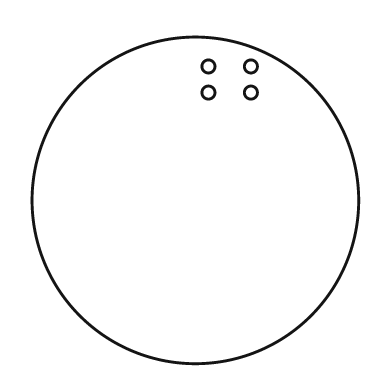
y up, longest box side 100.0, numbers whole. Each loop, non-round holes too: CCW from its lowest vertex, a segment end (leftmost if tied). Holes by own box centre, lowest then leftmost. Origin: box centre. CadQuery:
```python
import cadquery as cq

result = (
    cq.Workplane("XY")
    .moveTo(0.0, 0.0)
    .circle(50.0)
    .moveTo(4.0, 33.0)
    .circle(2.0)
    .moveTo(17.0, 33.0)
    .circle(2.0)
    .moveTo(4.0, 41.0)
    .circle(2.0)
    .moveTo(17.0, 41.0)
    .circle(2.0)
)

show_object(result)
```